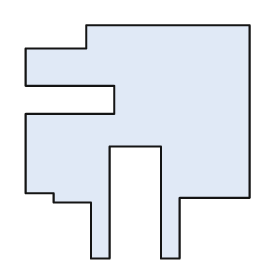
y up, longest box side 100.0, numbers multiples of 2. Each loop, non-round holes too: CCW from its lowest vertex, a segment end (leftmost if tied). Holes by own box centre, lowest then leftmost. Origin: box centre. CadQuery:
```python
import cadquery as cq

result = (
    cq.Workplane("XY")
    .moveTo(-20.0, -50.0)
    .lineTo(-12.0, -50.0)
    .lineTo(-12.0, -2.0)
    .lineTo(10.0, -2.0)
    .lineTo(10.0, -50.0)
    .lineTo(18.0, -50.0)
    .lineTo(18.0, -24.0)
    .lineTo(48.0, -24.0)
    .lineTo(48.0, 50.0)
    .lineTo(-22.0, 50.0)
    .lineTo(-22.0, 40.0)
    .lineTo(-48.0, 40.0)
    .lineTo(-48.0, 24.0)
    .lineTo(-10.0, 24.0)
    .lineTo(-10.0, 12.0)
    .lineTo(-48.0, 12.0)
    .lineTo(-48.0, -22.0)
    .lineTo(-36.0, -22.0)
    .lineTo(-36.0, -26.0)
    .lineTo(-20.0, -26.0)
    .close()
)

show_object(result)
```